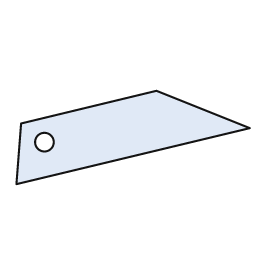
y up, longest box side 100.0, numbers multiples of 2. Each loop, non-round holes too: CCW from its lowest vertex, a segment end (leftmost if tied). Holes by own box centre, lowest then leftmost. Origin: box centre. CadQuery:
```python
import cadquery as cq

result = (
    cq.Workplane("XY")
    .moveTo(-50.0, -20.0)
    .lineTo(50.0, 4.0)
    .lineTo(10.0, 20.0)
    .lineTo(-48.0, 6.0)
    .close()
    .moveTo(-38.0, -2.0)
    .circle(4.0)
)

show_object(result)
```